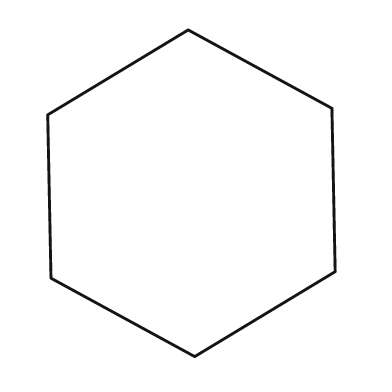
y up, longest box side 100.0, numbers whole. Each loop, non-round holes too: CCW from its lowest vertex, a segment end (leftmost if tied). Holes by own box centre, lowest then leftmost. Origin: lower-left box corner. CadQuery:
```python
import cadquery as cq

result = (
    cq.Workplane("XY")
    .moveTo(45.0, 0.0)
    .lineTo(88.0, 26.0)
    .lineTo(87.0, 76.0)
    .lineTo(43.0, 100.0)
    .lineTo(0.0, 74.0)
    .lineTo(1.0, 24.0)
    .close()
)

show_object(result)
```